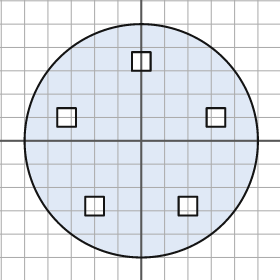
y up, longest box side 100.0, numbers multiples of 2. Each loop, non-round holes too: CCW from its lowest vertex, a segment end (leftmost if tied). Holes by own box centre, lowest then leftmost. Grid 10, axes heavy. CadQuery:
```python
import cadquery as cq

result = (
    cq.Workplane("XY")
    .moveTo(0.0, 0.0)
    .circle(50.0)
    .moveTo(-24.0, -32.0)
    .lineTo(-16.0, -32.0)
    .lineTo(-16.0, -24.0)
    .lineTo(-24.0, -24.0)
    .close()
    .moveTo(16.0, -32.0)
    .lineTo(24.0, -32.0)
    .lineTo(24.0, -24.0)
    .lineTo(16.0, -24.0)
    .close()
    .moveTo(-36.0, 6.0)
    .lineTo(-28.0, 6.0)
    .lineTo(-28.0, 14.0)
    .lineTo(-36.0, 14.0)
    .close()
    .moveTo(28.0, 6.0)
    .lineTo(36.0, 6.0)
    .lineTo(36.0, 14.0)
    .lineTo(28.0, 14.0)
    .close()
    .moveTo(-4.0, 30.0)
    .lineTo(4.0, 30.0)
    .lineTo(4.0, 38.0)
    .lineTo(-4.0, 38.0)
    .close()
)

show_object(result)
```